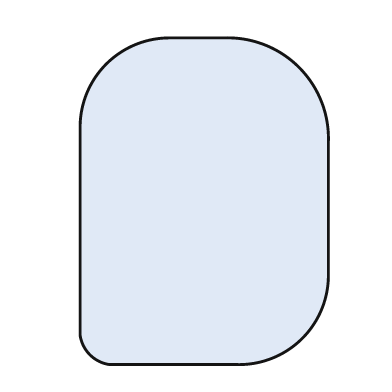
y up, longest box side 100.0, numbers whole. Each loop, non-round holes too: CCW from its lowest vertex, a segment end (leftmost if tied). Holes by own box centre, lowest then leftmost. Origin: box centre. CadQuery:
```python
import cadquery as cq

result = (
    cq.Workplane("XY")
    .moveTo(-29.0, -50.0)
    .lineTo(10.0, -50.0)
    .threePointArc((30.0, -42.0), (38.0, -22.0))
    .lineTo(38.0, 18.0)
    .threePointArc((29.0, 41.0), (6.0, 50.0))
    .lineTo(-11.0, 50.0)
    .threePointArc((-30.0, 42.0), (-38.0, 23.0))
    .lineTo(-38.0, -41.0)
    .threePointArc((-35.0, -47.0), (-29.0, -50.0))
    .close()
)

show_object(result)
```